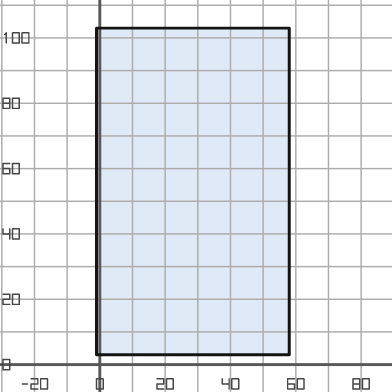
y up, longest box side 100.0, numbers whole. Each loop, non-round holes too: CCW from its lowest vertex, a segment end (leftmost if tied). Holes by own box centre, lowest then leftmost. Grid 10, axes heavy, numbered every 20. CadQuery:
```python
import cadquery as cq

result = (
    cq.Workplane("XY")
    .moveTo(-1.0, 3.0)
    .lineTo(58.0, 3.0)
    .lineTo(58.0, 103.0)
    .lineTo(-1.0, 103.0)
    .close()
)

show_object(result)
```